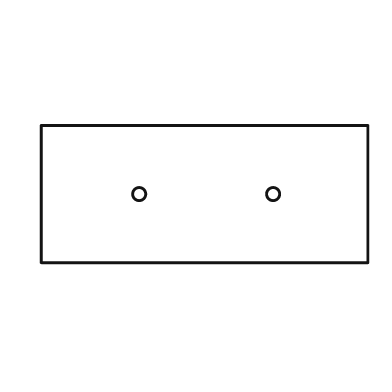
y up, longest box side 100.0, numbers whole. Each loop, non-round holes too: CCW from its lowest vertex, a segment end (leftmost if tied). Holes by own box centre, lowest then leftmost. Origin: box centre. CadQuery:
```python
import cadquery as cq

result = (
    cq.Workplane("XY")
    .moveTo(-50.0, -21.0)
    .lineTo(50.0, -21.0)
    .lineTo(50.0, 21.0)
    .lineTo(-50.0, 21.0)
    .close()
    .moveTo(-20.0, 0.0)
    .circle(2.0)
    .moveTo(21.0, 0.0)
    .circle(2.0)
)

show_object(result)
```